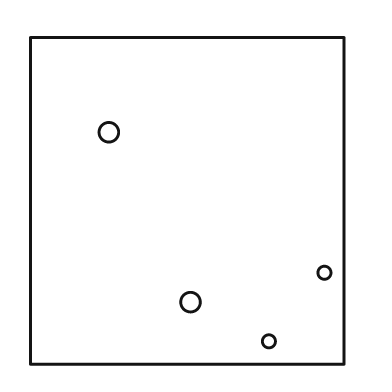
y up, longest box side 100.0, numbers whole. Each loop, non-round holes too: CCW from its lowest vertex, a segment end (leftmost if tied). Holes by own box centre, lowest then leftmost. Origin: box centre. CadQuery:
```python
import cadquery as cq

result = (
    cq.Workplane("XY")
    .moveTo(-48.0, -50.0)
    .lineTo(48.0, -50.0)
    .lineTo(48.0, 50.0)
    .lineTo(-48.0, 50.0)
    .close()
    .moveTo(25.0, -43.0)
    .circle(2.0)
    .moveTo(1.0, -31.0)
    .circle(3.0)
    .moveTo(42.0, -22.0)
    .circle(2.0)
    .moveTo(-24.0, 21.0)
    .circle(3.0)
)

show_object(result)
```